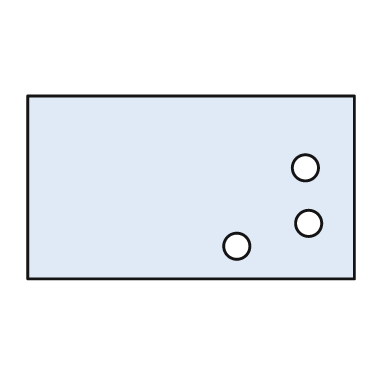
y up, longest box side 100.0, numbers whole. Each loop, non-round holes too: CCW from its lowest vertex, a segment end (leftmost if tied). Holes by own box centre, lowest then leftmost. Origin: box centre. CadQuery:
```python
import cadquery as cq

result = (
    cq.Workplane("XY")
    .moveTo(-50.0, -28.0)
    .lineTo(50.0, -28.0)
    .lineTo(50.0, 28.0)
    .lineTo(-50.0, 28.0)
    .close()
    .moveTo(14.0, -18.0)
    .circle(4.0)
    .moveTo(36.0, -11.0)
    .circle(4.0)
    .moveTo(35.0, 6.0)
    .circle(4.0)
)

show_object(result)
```